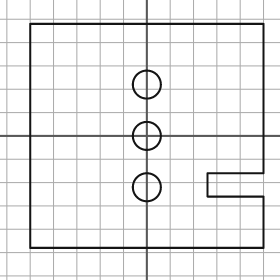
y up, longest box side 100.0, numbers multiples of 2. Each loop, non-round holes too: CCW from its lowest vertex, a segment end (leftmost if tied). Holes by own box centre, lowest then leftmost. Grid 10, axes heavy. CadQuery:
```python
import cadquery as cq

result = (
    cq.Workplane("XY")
    .moveTo(-50.0, -48.0)
    .lineTo(50.0, -48.0)
    .lineTo(50.0, -26.0)
    .lineTo(26.0, -26.0)
    .lineTo(26.0, -16.0)
    .lineTo(50.0, -16.0)
    .lineTo(50.0, 48.0)
    .lineTo(-50.0, 48.0)
    .close()
    .moveTo(0.0, -22.0)
    .circle(6.0)
    .moveTo(0.0, 0.0)
    .circle(6.0)
    .moveTo(0.0, 22.0)
    .circle(6.0)
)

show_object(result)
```